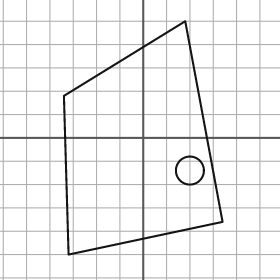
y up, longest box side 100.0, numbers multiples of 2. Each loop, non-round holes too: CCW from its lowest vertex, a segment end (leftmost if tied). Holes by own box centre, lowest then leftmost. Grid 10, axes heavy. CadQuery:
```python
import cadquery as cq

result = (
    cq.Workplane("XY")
    .moveTo(-32.0, -50.0)
    .lineTo(34.0, -36.0)
    .lineTo(18.0, 50.0)
    .lineTo(-34.0, 18.0)
    .close()
    .moveTo(20.0, -14.0)
    .circle(6.0)
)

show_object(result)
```